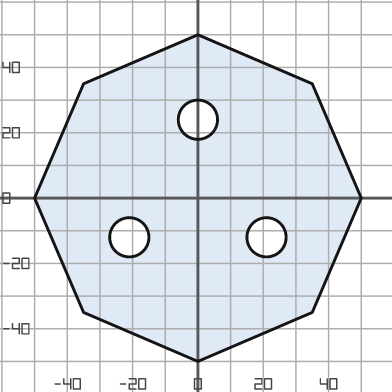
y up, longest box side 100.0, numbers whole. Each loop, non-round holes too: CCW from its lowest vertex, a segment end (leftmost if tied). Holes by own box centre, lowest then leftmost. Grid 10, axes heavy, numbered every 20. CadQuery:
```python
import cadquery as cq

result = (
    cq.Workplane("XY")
    .moveTo(0.0, -50.0)
    .lineTo(35.0, -35.0)
    .lineTo(50.0, 0.0)
    .lineTo(35.0, 35.0)
    .lineTo(0.0, 50.0)
    .lineTo(-35.0, 35.0)
    .lineTo(-50.0, 0.0)
    .lineTo(-35.0, -35.0)
    .close()
    .moveTo(-21.0, -12.0)
    .circle(6.0)
    .moveTo(21.0, -12.0)
    .circle(6.0)
    .moveTo(0.0, 24.0)
    .circle(6.0)
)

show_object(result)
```